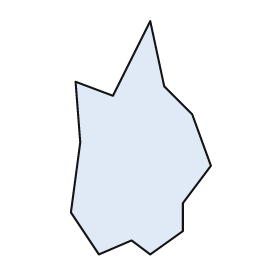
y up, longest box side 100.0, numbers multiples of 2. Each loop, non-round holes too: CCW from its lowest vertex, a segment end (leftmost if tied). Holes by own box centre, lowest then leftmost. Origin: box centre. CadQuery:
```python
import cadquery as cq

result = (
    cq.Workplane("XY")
    .moveTo(-18.0, -50.0)
    .lineTo(-4.0, -44.0)
    .lineTo(4.0, -50.0)
    .lineTo(18.0, -40.0)
    .lineTo(18.0, -28.0)
    .lineTo(30.0, -12.0)
    .lineTo(22.0, 10.0)
    .lineTo(10.0, 22.0)
    .lineTo(4.0, 50.0)
    .lineTo(-12.0, 18.0)
    .lineTo(-28.0, 24.0)
    .lineTo(-26.0, -2.0)
    .lineTo(-30.0, -32.0)
    .close()
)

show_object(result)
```